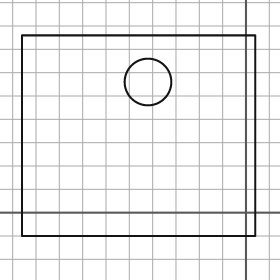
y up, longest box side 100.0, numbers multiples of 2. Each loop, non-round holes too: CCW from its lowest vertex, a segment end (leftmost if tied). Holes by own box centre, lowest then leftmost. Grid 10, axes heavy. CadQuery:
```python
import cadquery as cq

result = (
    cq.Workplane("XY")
    .moveTo(-96.0, -10.0)
    .lineTo(4.0, -10.0)
    .lineTo(4.0, 76.0)
    .lineTo(-96.0, 76.0)
    .close()
    .moveTo(-42.0, 56.0)
    .circle(10.0)
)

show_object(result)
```